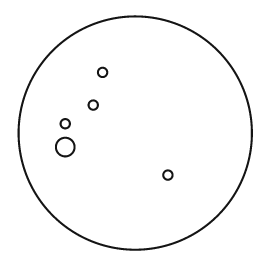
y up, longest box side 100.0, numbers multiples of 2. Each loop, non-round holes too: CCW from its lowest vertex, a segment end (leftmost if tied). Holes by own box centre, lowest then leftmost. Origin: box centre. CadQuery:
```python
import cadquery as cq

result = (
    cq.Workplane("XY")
    .moveTo(0.0, 0.0)
    .circle(50.0)
    .moveTo(14.0, -18.0)
    .circle(2.0)
    .moveTo(-30.0, -6.0)
    .circle(4.0)
    .moveTo(-30.0, 4.0)
    .circle(2.0)
    .moveTo(-18.0, 12.0)
    .circle(2.0)
    .moveTo(-14.0, 26.0)
    .circle(2.0)
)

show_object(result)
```